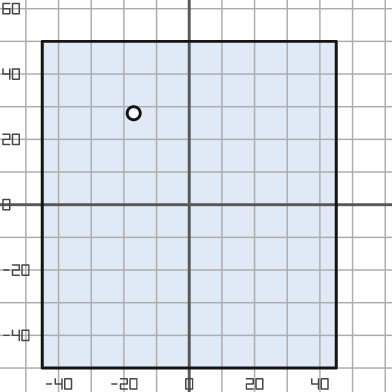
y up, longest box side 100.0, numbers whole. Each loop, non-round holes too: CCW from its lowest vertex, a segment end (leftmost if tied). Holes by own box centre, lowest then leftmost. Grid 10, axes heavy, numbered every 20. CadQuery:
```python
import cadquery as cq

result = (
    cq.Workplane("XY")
    .moveTo(-45.0, -50.0)
    .lineTo(45.0, -50.0)
    .lineTo(45.0, 50.0)
    .lineTo(-45.0, 50.0)
    .close()
    .moveTo(-17.0, 28.0)
    .circle(2.0)
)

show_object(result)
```